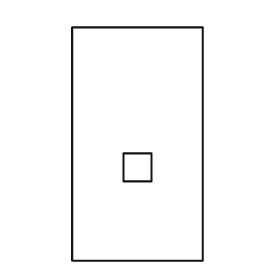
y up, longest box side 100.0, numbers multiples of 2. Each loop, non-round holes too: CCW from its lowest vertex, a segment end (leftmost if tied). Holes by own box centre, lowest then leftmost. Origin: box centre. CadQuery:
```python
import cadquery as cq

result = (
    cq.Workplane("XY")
    .moveTo(-28.0, -50.0)
    .lineTo(28.0, -50.0)
    .lineTo(28.0, 50.0)
    .lineTo(-28.0, 50.0)
    .close()
    .moveTo(-6.0, -16.0)
    .lineTo(6.0, -16.0)
    .lineTo(6.0, -4.0)
    .lineTo(-6.0, -4.0)
    .close()
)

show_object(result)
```